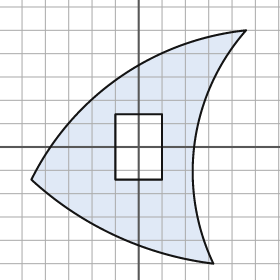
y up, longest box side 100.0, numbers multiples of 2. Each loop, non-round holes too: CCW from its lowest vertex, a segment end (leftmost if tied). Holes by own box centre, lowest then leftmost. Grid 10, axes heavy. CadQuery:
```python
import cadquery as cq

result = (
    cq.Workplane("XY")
    .moveTo(32.0, -50.0)
    .threePointArc((24.0, 2.0), (46.0, 50.0))
    .threePointArc((-8.0, 30.0), (-46.0, -14.0))
    .threePointArc((-10.0, -38.0), (32.0, -50.0))
    .close()
    .moveTo(-10.0, -14.0)
    .lineTo(10.0, -14.0)
    .lineTo(10.0, 14.0)
    .lineTo(-10.0, 14.0)
    .close()
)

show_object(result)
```